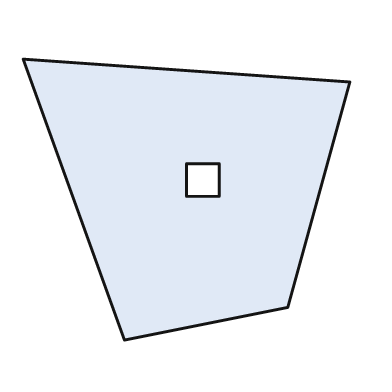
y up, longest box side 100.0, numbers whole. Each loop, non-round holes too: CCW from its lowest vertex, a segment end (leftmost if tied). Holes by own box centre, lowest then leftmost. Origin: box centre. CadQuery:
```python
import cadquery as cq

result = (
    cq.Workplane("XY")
    .moveTo(-19.0, -43.0)
    .lineTo(31.0, -33.0)
    .lineTo(50.0, 36.0)
    .lineTo(-50.0, 43.0)
    .close()
    .moveTo(0.0, 1.0)
    .lineTo(10.0, 1.0)
    .lineTo(10.0, 11.0)
    .lineTo(0.0, 11.0)
    .close()
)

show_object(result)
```